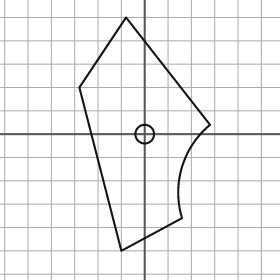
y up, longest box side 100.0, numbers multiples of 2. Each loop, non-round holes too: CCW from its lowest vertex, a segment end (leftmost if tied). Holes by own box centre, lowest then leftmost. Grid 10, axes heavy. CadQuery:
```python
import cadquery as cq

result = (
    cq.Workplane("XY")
    .moveTo(-10.0, -50.0)
    .lineTo(16.0, -36.0)
    .threePointArc((16.0, -14.0), (28.0, 4.0))
    .lineTo(-8.0, 50.0)
    .lineTo(-28.0, 20.0)
    .close()
    .moveTo(0.0, 0.0)
    .circle(4.0)
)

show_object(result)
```